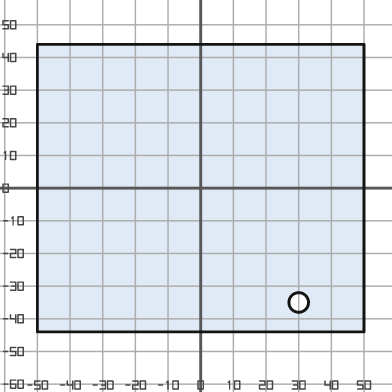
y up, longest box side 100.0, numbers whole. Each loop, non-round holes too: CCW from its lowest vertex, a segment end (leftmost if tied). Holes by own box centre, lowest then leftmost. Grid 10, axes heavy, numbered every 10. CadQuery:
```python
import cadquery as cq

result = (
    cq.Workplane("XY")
    .moveTo(-50.0, -44.0)
    .lineTo(50.0, -44.0)
    .lineTo(50.0, 44.0)
    .lineTo(-50.0, 44.0)
    .close()
    .moveTo(30.0, -35.0)
    .circle(3.0)
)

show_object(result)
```